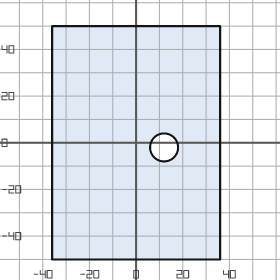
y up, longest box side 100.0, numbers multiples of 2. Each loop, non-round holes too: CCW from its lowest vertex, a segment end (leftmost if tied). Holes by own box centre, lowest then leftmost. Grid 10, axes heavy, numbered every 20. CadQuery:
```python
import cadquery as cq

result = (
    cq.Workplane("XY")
    .moveTo(-36.0, -50.0)
    .lineTo(36.0, -50.0)
    .lineTo(36.0, 50.0)
    .lineTo(-36.0, 50.0)
    .close()
    .moveTo(12.0, -2.0)
    .circle(6.0)
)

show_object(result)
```